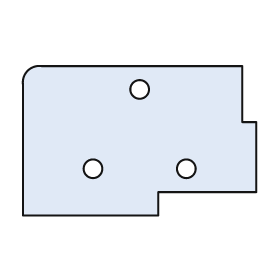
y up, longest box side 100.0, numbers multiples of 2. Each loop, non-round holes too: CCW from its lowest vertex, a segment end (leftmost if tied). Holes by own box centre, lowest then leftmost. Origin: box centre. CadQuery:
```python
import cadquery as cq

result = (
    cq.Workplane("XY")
    .moveTo(-50.0, -32.0)
    .lineTo(8.0, -32.0)
    .lineTo(8.0, -22.0)
    .lineTo(50.0, -22.0)
    .lineTo(50.0, 8.0)
    .lineTo(44.0, 8.0)
    .lineTo(44.0, 32.0)
    .lineTo(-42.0, 32.0)
    .threePointArc((-48.0, 30.0), (-50.0, 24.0))
    .close()
    .moveTo(-20.0, -12.0)
    .circle(4.0)
    .moveTo(20.0, -12.0)
    .circle(4.0)
    .moveTo(0.0, 22.0)
    .circle(4.0)
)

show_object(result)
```